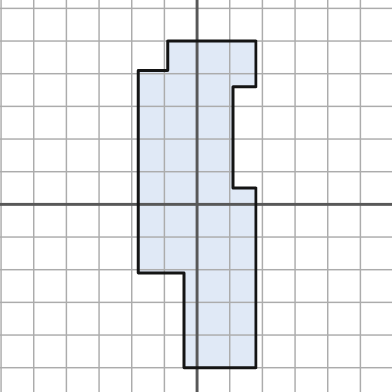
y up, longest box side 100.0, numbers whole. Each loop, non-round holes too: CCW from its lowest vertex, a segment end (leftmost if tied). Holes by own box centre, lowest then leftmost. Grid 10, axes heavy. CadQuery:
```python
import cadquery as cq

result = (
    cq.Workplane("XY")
    .moveTo(-4.0, -50.0)
    .lineTo(18.0, -50.0)
    .lineTo(18.0, 5.0)
    .lineTo(11.0, 5.0)
    .lineTo(11.0, 36.0)
    .lineTo(18.0, 36.0)
    .lineTo(18.0, 50.0)
    .lineTo(-9.0, 50.0)
    .lineTo(-9.0, 41.0)
    .lineTo(-18.0, 41.0)
    .lineTo(-18.0, -21.0)
    .lineTo(-4.0, -21.0)
    .close()
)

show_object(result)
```